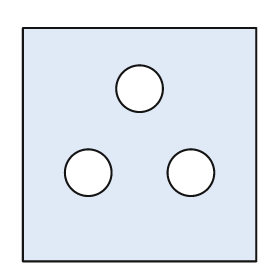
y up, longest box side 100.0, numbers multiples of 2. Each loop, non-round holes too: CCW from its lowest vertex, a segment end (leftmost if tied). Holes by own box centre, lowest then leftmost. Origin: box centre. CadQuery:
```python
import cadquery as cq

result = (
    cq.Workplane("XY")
    .moveTo(-50.0, -50.0)
    .lineTo(50.0, -50.0)
    .lineTo(50.0, 50.0)
    .lineTo(-50.0, 50.0)
    .close()
    .moveTo(-22.0, -12.0)
    .circle(10.0)
    .moveTo(22.0, -12.0)
    .circle(10.0)
    .moveTo(0.0, 24.0)
    .circle(10.0)
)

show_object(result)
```